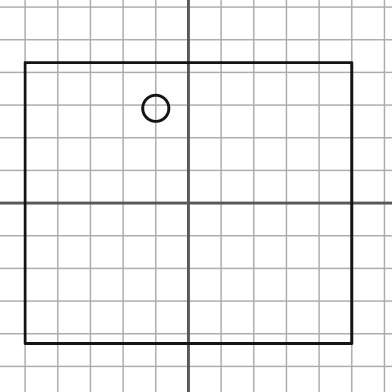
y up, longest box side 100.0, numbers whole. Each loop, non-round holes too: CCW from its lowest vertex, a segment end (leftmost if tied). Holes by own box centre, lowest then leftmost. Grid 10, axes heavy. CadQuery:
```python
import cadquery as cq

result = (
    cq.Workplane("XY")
    .moveTo(-50.0, -43.0)
    .lineTo(50.0, -43.0)
    .lineTo(50.0, 43.0)
    .lineTo(-50.0, 43.0)
    .close()
    .moveTo(-10.0, 29.0)
    .circle(4.0)
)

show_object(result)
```